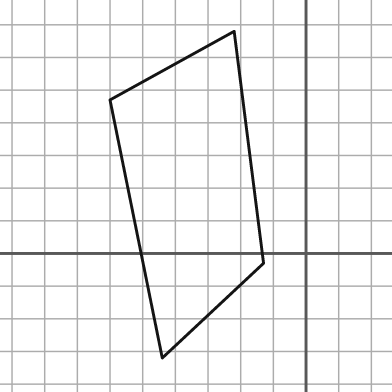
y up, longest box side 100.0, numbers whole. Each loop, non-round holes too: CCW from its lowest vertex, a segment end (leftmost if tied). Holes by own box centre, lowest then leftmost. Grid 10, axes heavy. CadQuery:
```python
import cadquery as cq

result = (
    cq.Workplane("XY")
    .moveTo(-44.0, -32.0)
    .lineTo(-13.0, -3.0)
    .lineTo(-22.0, 68.0)
    .lineTo(-60.0, 47.0)
    .close()
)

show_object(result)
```